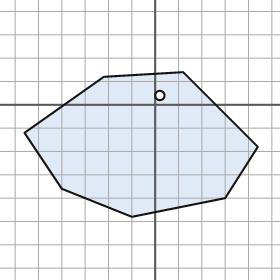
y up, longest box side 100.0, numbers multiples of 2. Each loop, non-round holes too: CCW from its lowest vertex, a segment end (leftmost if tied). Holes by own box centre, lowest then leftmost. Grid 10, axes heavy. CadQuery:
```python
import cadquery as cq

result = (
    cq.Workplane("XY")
    .moveTo(-10.0, -48.0)
    .lineTo(30.0, -40.0)
    .lineTo(44.0, -18.0)
    .lineTo(12.0, 14.0)
    .lineTo(-22.0, 12.0)
    .lineTo(-56.0, -12.0)
    .lineTo(-40.0, -36.0)
    .close()
    .moveTo(2.0, 4.0)
    .circle(2.0)
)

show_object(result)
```